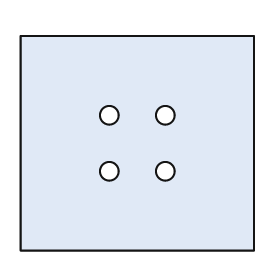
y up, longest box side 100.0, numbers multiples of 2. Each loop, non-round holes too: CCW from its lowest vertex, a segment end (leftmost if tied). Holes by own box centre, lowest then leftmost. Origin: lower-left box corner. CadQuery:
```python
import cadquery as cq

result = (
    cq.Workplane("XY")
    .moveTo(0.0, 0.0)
    .lineTo(100.0, 0.0)
    .lineTo(100.0, 92.0)
    .lineTo(0.0, 92.0)
    .close()
    .moveTo(38.0, 34.0)
    .circle(4.0)
    .moveTo(62.0, 34.0)
    .circle(4.0)
    .moveTo(38.0, 58.0)
    .circle(4.0)
    .moveTo(62.0, 58.0)
    .circle(4.0)
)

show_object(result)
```